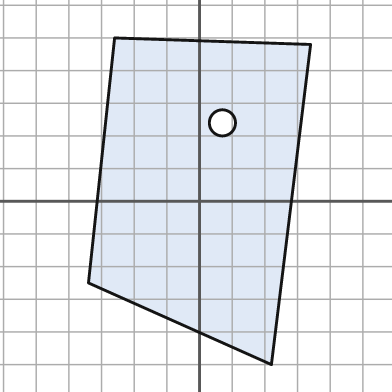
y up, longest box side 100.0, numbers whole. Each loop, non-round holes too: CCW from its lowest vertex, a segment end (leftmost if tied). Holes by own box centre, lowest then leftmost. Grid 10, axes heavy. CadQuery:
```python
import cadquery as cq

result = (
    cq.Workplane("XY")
    .moveTo(22.0, -50.0)
    .lineTo(34.0, 48.0)
    .lineTo(-26.0, 50.0)
    .lineTo(-34.0, -25.0)
    .close()
    .moveTo(7.0, 24.0)
    .circle(4.0)
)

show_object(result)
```